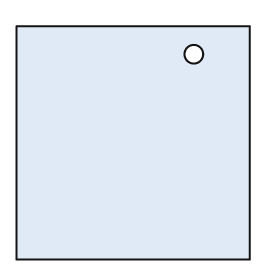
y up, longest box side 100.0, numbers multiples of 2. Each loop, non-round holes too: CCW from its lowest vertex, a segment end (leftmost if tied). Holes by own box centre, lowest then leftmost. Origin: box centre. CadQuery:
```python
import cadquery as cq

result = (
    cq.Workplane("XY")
    .moveTo(-50.0, -50.0)
    .lineTo(50.0, -50.0)
    .lineTo(50.0, 50.0)
    .lineTo(-50.0, 50.0)
    .close()
    .moveTo(26.0, 38.0)
    .circle(4.0)
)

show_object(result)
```